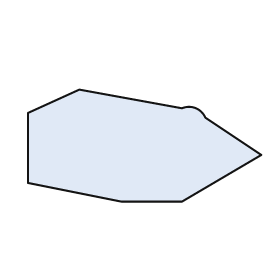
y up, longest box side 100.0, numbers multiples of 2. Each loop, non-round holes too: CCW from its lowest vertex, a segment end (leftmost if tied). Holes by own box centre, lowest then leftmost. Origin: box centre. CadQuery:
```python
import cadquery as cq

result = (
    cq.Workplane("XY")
    .moveTo(-10.0, -24.0)
    .lineTo(16.0, -24.0)
    .lineTo(50.0, -4.0)
    .lineTo(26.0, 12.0)
    .threePointArc((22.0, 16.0), (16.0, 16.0))
    .lineTo(-28.0, 24.0)
    .lineTo(-50.0, 14.0)
    .lineTo(-50.0, -16.0)
    .close()
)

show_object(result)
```